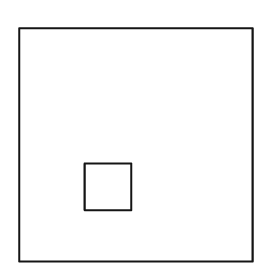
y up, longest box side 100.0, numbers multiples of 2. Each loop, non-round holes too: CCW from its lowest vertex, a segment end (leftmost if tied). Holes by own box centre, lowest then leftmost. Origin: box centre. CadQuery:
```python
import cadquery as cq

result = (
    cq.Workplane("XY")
    .moveTo(-50.0, -50.0)
    .lineTo(50.0, -50.0)
    .lineTo(50.0, 50.0)
    .lineTo(-50.0, 50.0)
    .close()
    .moveTo(-22.0, -28.0)
    .lineTo(-2.0, -28.0)
    .lineTo(-2.0, -8.0)
    .lineTo(-22.0, -8.0)
    .close()
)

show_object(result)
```